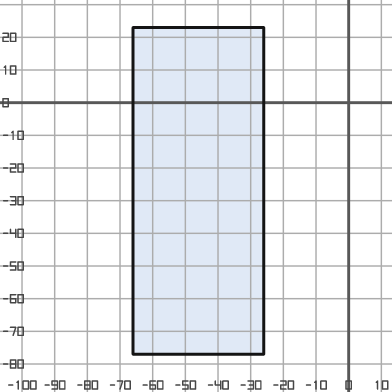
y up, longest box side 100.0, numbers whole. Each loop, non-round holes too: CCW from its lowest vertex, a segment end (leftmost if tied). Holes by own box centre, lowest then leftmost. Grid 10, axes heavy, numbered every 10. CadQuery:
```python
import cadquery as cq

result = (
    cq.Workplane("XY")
    .moveTo(-66.0, -77.0)
    .lineTo(-26.0, -77.0)
    .lineTo(-26.0, 23.0)
    .lineTo(-66.0, 23.0)
    .close()
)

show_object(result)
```